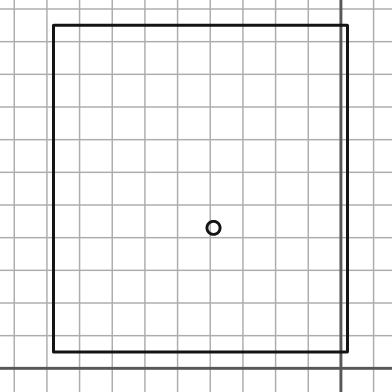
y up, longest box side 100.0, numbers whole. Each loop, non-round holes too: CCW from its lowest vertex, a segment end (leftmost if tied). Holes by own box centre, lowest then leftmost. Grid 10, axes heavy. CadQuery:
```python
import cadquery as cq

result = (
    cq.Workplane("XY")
    .moveTo(-88.0, 5.0)
    .lineTo(2.0, 5.0)
    .lineTo(2.0, 105.0)
    .lineTo(-88.0, 105.0)
    .close()
    .moveTo(-39.0, 43.0)
    .circle(2.0)
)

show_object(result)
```